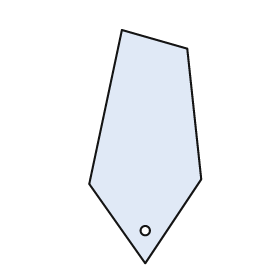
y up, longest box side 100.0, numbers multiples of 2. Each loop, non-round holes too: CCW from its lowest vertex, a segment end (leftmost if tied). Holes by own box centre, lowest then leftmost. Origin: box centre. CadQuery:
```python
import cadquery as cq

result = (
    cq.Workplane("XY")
    .moveTo(0.0, -50.0)
    .lineTo(24.0, -14.0)
    .lineTo(18.0, 42.0)
    .lineTo(-10.0, 50.0)
    .lineTo(-24.0, -16.0)
    .close()
    .moveTo(0.0, -36.0)
    .circle(2.0)
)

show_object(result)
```